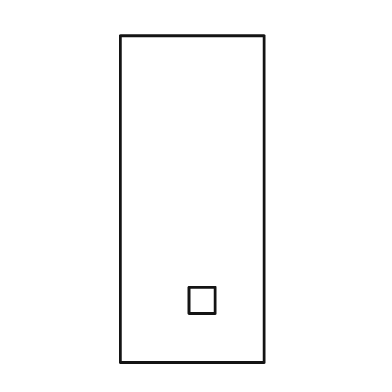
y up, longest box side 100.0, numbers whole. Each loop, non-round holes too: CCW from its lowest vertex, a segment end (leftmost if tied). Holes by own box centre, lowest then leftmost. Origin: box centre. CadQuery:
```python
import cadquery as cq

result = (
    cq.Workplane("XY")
    .moveTo(-22.0, -50.0)
    .lineTo(22.0, -50.0)
    .lineTo(22.0, 50.0)
    .lineTo(-22.0, 50.0)
    .close()
    .moveTo(-1.0, -35.0)
    .lineTo(7.0, -35.0)
    .lineTo(7.0, -27.0)
    .lineTo(-1.0, -27.0)
    .close()
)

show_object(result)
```